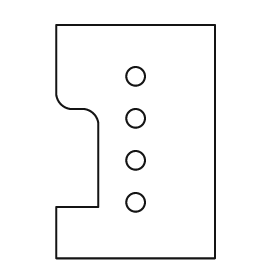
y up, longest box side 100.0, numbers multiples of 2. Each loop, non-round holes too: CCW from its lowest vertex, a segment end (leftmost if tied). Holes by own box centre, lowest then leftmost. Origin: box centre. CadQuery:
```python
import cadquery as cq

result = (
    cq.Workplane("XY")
    .moveTo(-34.0, -50.0)
    .lineTo(34.0, -50.0)
    .lineTo(34.0, 50.0)
    .lineTo(-34.0, 50.0)
    .lineTo(-34.0, 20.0)
    .threePointArc((-32.0, 16.0), (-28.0, 14.0))
    .lineTo(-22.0, 14.0)
    .threePointArc((-18.0, 12.0), (-16.0, 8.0))
    .lineTo(-16.0, -28.0)
    .lineTo(-34.0, -28.0)
    .close()
    .moveTo(0.0, -26.0)
    .circle(4.0)
    .moveTo(0.0, -8.0)
    .circle(4.0)
    .moveTo(0.0, 10.0)
    .circle(4.0)
    .moveTo(0.0, 28.0)
    .circle(4.0)
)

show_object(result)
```